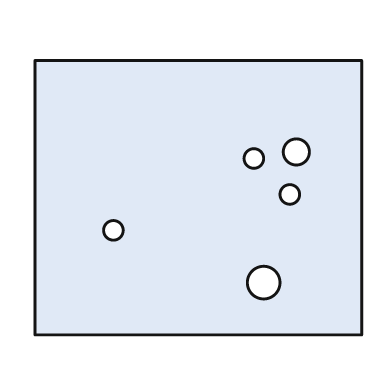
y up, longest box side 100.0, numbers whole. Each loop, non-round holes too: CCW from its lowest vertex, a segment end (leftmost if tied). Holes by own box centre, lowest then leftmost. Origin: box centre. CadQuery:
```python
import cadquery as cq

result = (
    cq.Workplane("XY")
    .moveTo(-50.0, -42.0)
    .lineTo(50.0, -42.0)
    .lineTo(50.0, 42.0)
    .lineTo(-50.0, 42.0)
    .close()
    .moveTo(20.0, -26.0)
    .circle(5.0)
    .moveTo(-26.0, -10.0)
    .circle(3.0)
    .moveTo(28.0, 1.0)
    .circle(3.0)
    .moveTo(17.0, 12.0)
    .circle(3.0)
    .moveTo(30.0, 14.0)
    .circle(4.0)
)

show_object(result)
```